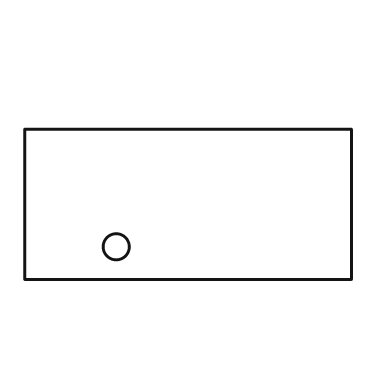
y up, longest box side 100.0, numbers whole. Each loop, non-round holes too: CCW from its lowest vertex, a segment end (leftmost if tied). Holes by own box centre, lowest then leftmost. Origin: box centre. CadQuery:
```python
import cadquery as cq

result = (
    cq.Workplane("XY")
    .moveTo(-50.0, -23.0)
    .lineTo(50.0, -23.0)
    .lineTo(50.0, 23.0)
    .lineTo(-50.0, 23.0)
    .close()
    .moveTo(-22.0, -13.0)
    .circle(4.0)
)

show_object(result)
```